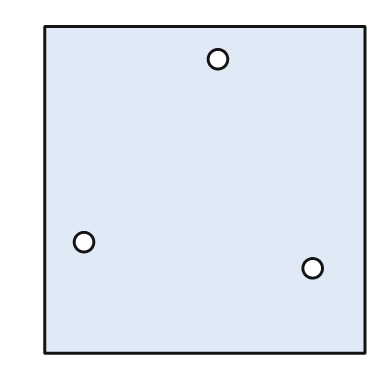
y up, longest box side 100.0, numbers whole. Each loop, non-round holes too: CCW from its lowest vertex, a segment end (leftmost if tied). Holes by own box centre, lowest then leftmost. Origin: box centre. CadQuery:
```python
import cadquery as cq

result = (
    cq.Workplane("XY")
    .moveTo(-49.0, -50.0)
    .lineTo(49.0, -50.0)
    .lineTo(49.0, 50.0)
    .lineTo(-49.0, 50.0)
    .close()
    .moveTo(33.0, -24.0)
    .circle(3.0)
    .moveTo(-37.0, -16.0)
    .circle(3.0)
    .moveTo(4.0, 40.0)
    .circle(3.0)
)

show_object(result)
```